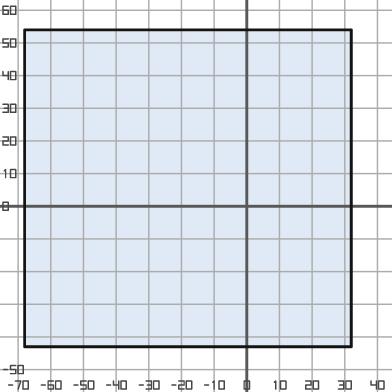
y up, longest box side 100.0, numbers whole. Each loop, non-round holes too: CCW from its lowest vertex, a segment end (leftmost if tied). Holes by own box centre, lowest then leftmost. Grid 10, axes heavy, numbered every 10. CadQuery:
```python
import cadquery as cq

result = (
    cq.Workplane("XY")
    .moveTo(-68.0, -43.0)
    .lineTo(32.0, -43.0)
    .lineTo(32.0, 54.0)
    .lineTo(-68.0, 54.0)
    .close()
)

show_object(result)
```